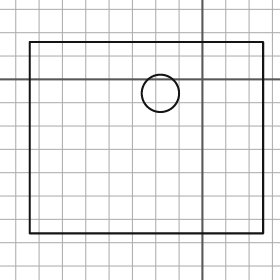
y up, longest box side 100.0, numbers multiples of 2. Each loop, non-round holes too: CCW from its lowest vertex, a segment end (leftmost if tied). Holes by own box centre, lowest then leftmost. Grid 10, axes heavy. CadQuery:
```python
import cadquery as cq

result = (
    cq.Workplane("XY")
    .moveTo(-74.0, -66.0)
    .lineTo(26.0, -66.0)
    .lineTo(26.0, 16.0)
    .lineTo(-74.0, 16.0)
    .close()
    .moveTo(-18.0, -6.0)
    .circle(8.0)
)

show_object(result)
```